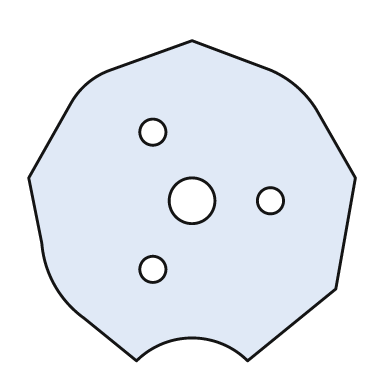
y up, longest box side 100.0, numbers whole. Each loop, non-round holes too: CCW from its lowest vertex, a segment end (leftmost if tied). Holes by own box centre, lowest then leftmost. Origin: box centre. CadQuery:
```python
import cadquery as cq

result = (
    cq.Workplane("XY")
    .moveTo(-17.0, -49.0)
    .threePointArc((0.0, -42.0), (17.0, -49.0))
    .lineTo(44.0, -27.0)
    .lineTo(50.0, 7.0)
    .lineTo(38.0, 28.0)
    .threePointArc((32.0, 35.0), (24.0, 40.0))
    .lineTo(0.0, 49.0)
    .lineTo(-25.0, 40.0)
    .threePointArc((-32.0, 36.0), (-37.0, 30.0))
    .lineTo(-50.0, 7.0)
    .lineTo(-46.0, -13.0)
    .threePointArc((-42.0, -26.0), (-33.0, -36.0))
    .close()
    .moveTo(-12.0, -21.0)
    .circle(4.0)
    .moveTo(0.0, 0.0)
    .circle(7.0)
    .moveTo(24.0, 0.0)
    .circle(4.0)
    .moveTo(-12.0, 21.0)
    .circle(4.0)
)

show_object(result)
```